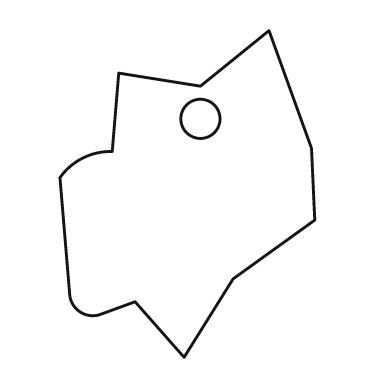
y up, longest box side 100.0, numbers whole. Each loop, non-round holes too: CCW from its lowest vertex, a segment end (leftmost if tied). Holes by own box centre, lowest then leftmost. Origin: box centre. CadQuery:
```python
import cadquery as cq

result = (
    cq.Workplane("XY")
    .moveTo(-1.0, -50.0)
    .lineTo(14.0, -26.0)
    .lineTo(39.0, -8.0)
    .lineTo(38.0, 14.0)
    .lineTo(25.0, 50.0)
    .lineTo(4.0, 33.0)
    .lineTo(-21.0, 37.0)
    .lineTo(-23.0, 13.0)
    .threePointArc((-32.0, 11.0), (-39.0, 5.0))
    .lineTo(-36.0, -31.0)
    .threePointArc((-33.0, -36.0), (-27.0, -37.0))
    .lineTo(-16.0, -33.0)
    .close()
    .moveTo(4.0, 23.0)
    .circle(6.0)
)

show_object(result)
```